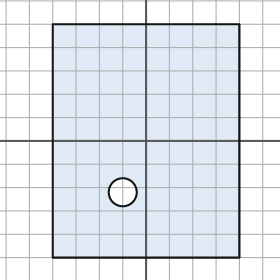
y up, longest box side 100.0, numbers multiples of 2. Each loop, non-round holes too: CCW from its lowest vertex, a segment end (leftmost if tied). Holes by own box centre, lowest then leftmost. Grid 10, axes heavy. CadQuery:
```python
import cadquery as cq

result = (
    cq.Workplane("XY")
    .moveTo(-40.0, -50.0)
    .lineTo(40.0, -50.0)
    .lineTo(40.0, 50.0)
    .lineTo(-40.0, 50.0)
    .close()
    .moveTo(-10.0, -22.0)
    .circle(6.0)
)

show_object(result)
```